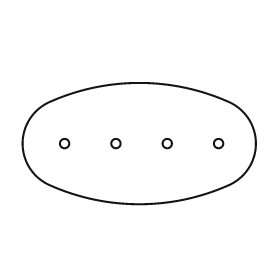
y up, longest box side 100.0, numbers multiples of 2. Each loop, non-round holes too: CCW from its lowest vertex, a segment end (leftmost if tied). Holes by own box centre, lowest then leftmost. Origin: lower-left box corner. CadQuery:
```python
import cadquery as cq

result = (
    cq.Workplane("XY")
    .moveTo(12.0, 8.0)
    .threePointArc((50.0, 0.0), (88.0, 8.0))
    .threePointArc((100.0, 26.0), (88.0, 44.0))
    .threePointArc((50.0, 52.0), (12.0, 44.0))
    .threePointArc((0.0, 26.0), (12.0, 8.0))
    .close()
    .moveTo(18.0, 26.0)
    .circle(2.0)
    .moveTo(40.0, 26.0)
    .circle(2.0)
    .moveTo(62.0, 26.0)
    .circle(2.0)
    .moveTo(84.0, 26.0)
    .circle(2.0)
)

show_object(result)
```